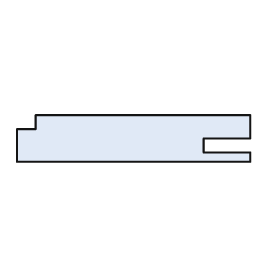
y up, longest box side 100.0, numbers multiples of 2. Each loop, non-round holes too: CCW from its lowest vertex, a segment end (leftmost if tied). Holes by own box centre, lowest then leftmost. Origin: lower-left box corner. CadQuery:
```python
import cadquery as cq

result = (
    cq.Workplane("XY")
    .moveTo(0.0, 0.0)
    .lineTo(100.0, 0.0)
    .lineTo(100.0, 4.0)
    .lineTo(80.0, 4.0)
    .lineTo(80.0, 10.0)
    .lineTo(100.0, 10.0)
    .lineTo(100.0, 20.0)
    .lineTo(8.0, 20.0)
    .lineTo(8.0, 14.0)
    .lineTo(0.0, 14.0)
    .close()
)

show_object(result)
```